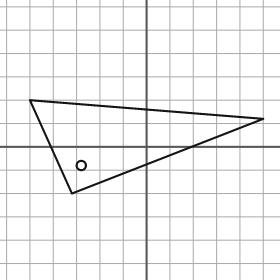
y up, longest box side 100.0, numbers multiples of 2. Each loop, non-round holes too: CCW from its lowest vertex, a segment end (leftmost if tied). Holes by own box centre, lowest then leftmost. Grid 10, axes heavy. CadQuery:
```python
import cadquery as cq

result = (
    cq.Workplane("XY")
    .moveTo(-32.0, -20.0)
    .lineTo(50.0, 12.0)
    .lineTo(-50.0, 20.0)
    .close()
    .moveTo(-28.0, -8.0)
    .circle(2.0)
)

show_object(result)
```